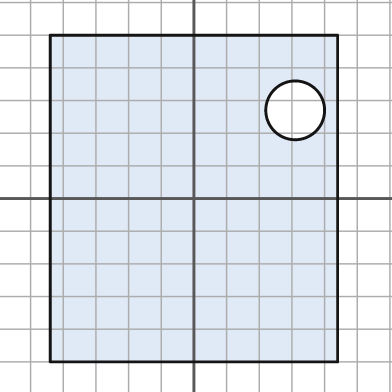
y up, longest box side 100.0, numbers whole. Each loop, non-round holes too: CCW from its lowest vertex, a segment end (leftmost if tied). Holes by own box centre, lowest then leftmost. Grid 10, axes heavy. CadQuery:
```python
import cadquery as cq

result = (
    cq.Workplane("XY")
    .moveTo(-44.0, -50.0)
    .lineTo(44.0, -50.0)
    .lineTo(44.0, 50.0)
    .lineTo(-44.0, 50.0)
    .close()
    .moveTo(31.0, 27.0)
    .circle(9.0)
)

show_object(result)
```